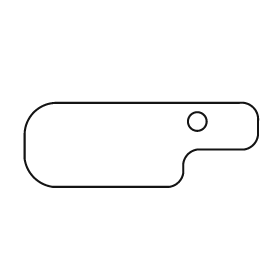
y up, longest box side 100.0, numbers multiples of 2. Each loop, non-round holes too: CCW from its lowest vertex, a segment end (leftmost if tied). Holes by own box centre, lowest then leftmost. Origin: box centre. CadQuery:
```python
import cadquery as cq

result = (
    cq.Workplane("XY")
    .moveTo(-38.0, -18.0)
    .lineTo(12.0, -18.0)
    .threePointArc((16.0, -16.0), (18.0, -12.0))
    .lineTo(18.0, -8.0)
    .threePointArc((20.0, -4.0), (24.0, -2.0))
    .lineTo(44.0, -2.0)
    .threePointArc((48.0, 0.0), (50.0, 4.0))
    .lineTo(50.0, 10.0)
    .threePointArc((48.0, 16.0), (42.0, 18.0))
    .lineTo(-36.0, 18.0)
    .threePointArc((-46.0, 14.0), (-50.0, 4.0))
    .lineTo(-50.0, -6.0)
    .threePointArc((-46.0, -14.0), (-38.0, -18.0))
    .close()
    .moveTo(24.0, 10.0)
    .circle(4.0)
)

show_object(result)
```